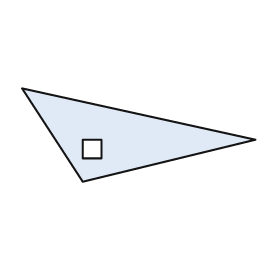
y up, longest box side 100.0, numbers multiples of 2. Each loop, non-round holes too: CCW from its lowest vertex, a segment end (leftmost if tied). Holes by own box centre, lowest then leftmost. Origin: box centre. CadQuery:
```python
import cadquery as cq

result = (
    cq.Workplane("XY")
    .moveTo(-24.0, -20.0)
    .lineTo(50.0, -2.0)
    .lineTo(-50.0, 20.0)
    .close()
    .moveTo(-24.0, -10.0)
    .lineTo(-16.0, -10.0)
    .lineTo(-16.0, -2.0)
    .lineTo(-24.0, -2.0)
    .close()
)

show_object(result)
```